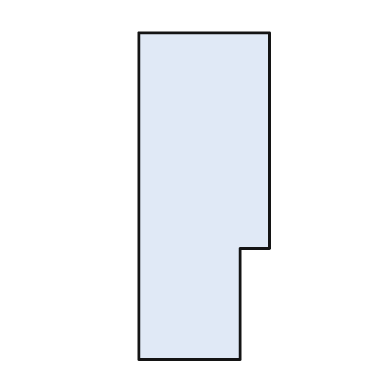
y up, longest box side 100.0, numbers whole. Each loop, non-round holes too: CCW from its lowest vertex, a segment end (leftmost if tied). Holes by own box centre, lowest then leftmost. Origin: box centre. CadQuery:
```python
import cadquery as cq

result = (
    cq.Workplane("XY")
    .moveTo(-20.0, -50.0)
    .lineTo(11.0, -50.0)
    .lineTo(11.0, -16.0)
    .lineTo(20.0, -16.0)
    .lineTo(20.0, 50.0)
    .lineTo(-20.0, 50.0)
    .close()
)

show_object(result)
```